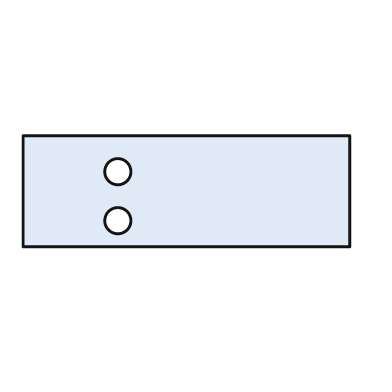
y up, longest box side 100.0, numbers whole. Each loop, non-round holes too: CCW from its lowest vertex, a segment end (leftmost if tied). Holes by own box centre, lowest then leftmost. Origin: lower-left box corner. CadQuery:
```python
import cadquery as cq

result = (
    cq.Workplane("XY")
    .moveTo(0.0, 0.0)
    .lineTo(100.0, 0.0)
    .lineTo(100.0, 34.0)
    .lineTo(0.0, 34.0)
    .close()
    .moveTo(29.0, 8.0)
    .circle(4.0)
    .moveTo(29.0, 23.0)
    .circle(4.0)
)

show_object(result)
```